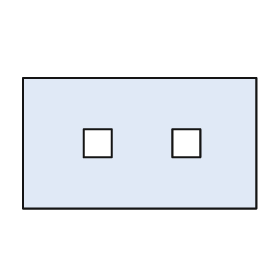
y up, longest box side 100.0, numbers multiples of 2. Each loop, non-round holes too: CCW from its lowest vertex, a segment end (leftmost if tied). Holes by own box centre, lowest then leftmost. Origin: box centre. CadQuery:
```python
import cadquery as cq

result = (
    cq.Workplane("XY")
    .moveTo(-50.0, -28.0)
    .lineTo(50.0, -28.0)
    .lineTo(50.0, 28.0)
    .lineTo(-50.0, 28.0)
    .close()
    .moveTo(-24.0, -6.0)
    .lineTo(-12.0, -6.0)
    .lineTo(-12.0, 6.0)
    .lineTo(-24.0, 6.0)
    .close()
    .moveTo(14.0, -6.0)
    .lineTo(26.0, -6.0)
    .lineTo(26.0, 6.0)
    .lineTo(14.0, 6.0)
    .close()
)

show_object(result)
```